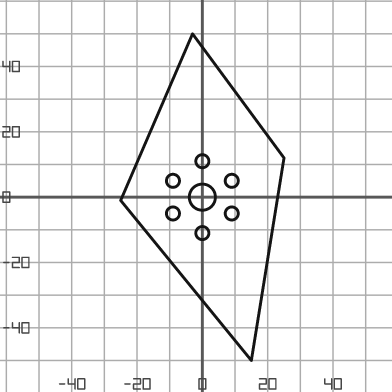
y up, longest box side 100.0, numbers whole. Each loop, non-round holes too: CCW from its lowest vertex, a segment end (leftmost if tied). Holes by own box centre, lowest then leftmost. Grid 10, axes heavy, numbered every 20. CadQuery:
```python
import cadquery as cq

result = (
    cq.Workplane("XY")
    .moveTo(15.0, -50.0)
    .lineTo(25.0, 12.0)
    .lineTo(-3.0, 50.0)
    .lineTo(-25.0, -1.0)
    .close()
    .moveTo(0.0, -11.0)
    .circle(2.0)
    .moveTo(-9.0, -5.0)
    .circle(2.0)
    .moveTo(9.0, -5.0)
    .circle(2.0)
    .moveTo(0.0, 0.0)
    .circle(4.0)
    .moveTo(-9.0, 5.0)
    .circle(2.0)
    .moveTo(9.0, 5.0)
    .circle(2.0)
    .moveTo(0.0, 11.0)
    .circle(2.0)
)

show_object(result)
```